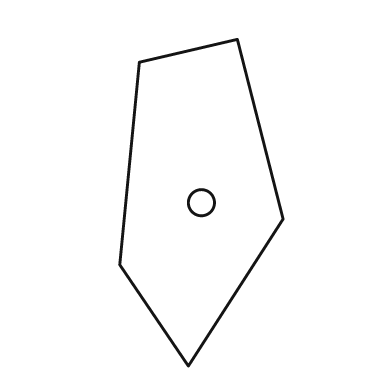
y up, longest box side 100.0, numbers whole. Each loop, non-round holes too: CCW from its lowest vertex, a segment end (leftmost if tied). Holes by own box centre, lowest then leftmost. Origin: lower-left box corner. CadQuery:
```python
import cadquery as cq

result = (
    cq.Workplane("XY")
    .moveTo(21.0, 0.0)
    .lineTo(50.0, 45.0)
    .lineTo(36.0, 100.0)
    .lineTo(6.0, 93.0)
    .lineTo(0.0, 31.0)
    .close()
    .moveTo(25.0, 50.0)
    .circle(4.0)
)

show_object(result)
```